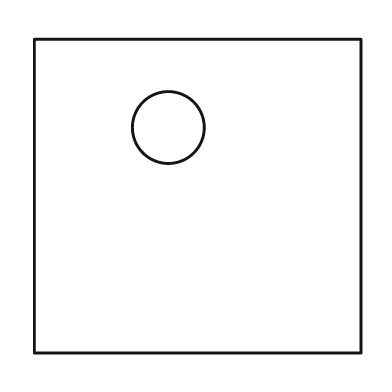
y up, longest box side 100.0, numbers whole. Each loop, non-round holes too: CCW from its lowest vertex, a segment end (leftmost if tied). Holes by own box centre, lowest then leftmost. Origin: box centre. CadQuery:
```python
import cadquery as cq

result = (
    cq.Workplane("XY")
    .moveTo(-50.0, -48.0)
    .lineTo(50.0, -48.0)
    .lineTo(50.0, 48.0)
    .lineTo(-50.0, 48.0)
    .close()
    .moveTo(-9.0, 21.0)
    .circle(11.0)
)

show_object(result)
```